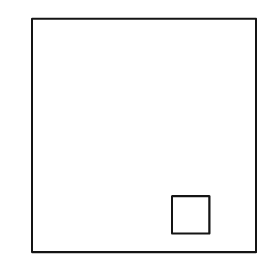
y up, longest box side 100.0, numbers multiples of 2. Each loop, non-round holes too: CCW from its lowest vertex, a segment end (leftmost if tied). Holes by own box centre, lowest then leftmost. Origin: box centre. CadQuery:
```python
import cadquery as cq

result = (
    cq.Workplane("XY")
    .moveTo(-48.0, -50.0)
    .lineTo(48.0, -50.0)
    .lineTo(48.0, 50.0)
    .lineTo(-48.0, 50.0)
    .close()
    .moveTo(12.0, -42.0)
    .lineTo(28.0, -42.0)
    .lineTo(28.0, -26.0)
    .lineTo(12.0, -26.0)
    .close()
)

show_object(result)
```